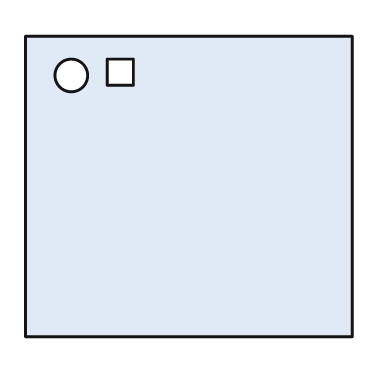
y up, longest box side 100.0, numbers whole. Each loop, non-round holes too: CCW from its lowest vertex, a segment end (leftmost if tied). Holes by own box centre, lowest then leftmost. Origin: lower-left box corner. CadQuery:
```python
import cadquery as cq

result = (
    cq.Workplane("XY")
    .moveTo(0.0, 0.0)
    .lineTo(100.0, 0.0)
    .lineTo(100.0, 92.0)
    .lineTo(0.0, 92.0)
    .close()
    .moveTo(14.0, 80.0)
    .circle(5.0)
    .moveTo(25.0, 77.0)
    .lineTo(33.0, 77.0)
    .lineTo(33.0, 85.0)
    .lineTo(25.0, 85.0)
    .close()
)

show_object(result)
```